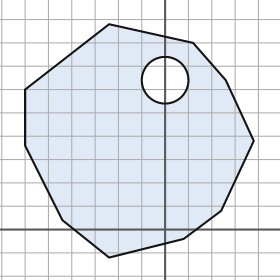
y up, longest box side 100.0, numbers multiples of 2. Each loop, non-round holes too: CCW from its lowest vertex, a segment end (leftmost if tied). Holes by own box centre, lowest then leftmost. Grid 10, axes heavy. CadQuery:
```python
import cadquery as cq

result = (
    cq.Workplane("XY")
    .moveTo(-24.0, -12.0)
    .lineTo(8.0, -4.0)
    .lineTo(24.0, 8.0)
    .lineTo(38.0, 38.0)
    .lineTo(26.0, 64.0)
    .lineTo(12.0, 80.0)
    .lineTo(-24.0, 88.0)
    .lineTo(-60.0, 60.0)
    .lineTo(-60.0, 36.0)
    .lineTo(-44.0, 4.0)
    .close()
    .moveTo(0.0, 64.0)
    .circle(10.0)
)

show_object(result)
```